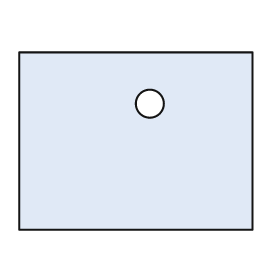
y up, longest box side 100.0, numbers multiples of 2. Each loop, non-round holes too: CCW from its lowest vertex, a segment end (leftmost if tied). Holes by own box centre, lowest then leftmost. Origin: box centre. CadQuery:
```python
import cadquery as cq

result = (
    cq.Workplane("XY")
    .moveTo(-50.0, -38.0)
    .lineTo(50.0, -38.0)
    .lineTo(50.0, 38.0)
    .lineTo(-50.0, 38.0)
    .close()
    .moveTo(6.0, 16.0)
    .circle(6.0)
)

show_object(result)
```